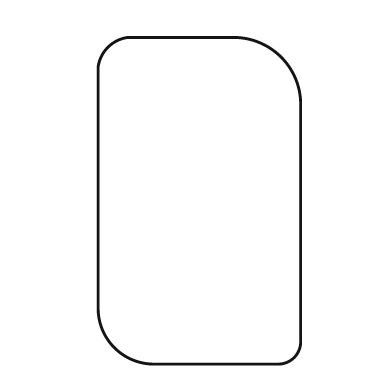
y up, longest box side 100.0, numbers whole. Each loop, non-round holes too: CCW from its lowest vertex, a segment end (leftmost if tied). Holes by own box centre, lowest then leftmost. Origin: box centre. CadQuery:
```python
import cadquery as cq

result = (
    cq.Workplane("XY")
    .moveTo(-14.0, -50.0)
    .lineTo(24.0, -50.0)
    .threePointArc((29.0, -48.0), (31.0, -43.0))
    .lineTo(31.0, 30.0)
    .threePointArc((25.0, 44.0), (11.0, 50.0))
    .lineTo(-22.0, 50.0)
    .threePointArc((-28.0, 47.0), (-31.0, 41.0))
    .lineTo(-31.0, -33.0)
    .threePointArc((-26.0, -45.0), (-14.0, -50.0))
    .close()
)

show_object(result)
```